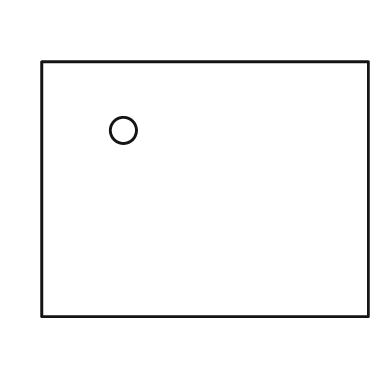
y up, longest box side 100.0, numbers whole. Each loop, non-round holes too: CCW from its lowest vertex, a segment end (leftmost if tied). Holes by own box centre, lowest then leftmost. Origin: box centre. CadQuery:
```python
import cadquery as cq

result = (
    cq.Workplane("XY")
    .moveTo(-50.0, -39.0)
    .lineTo(50.0, -39.0)
    .lineTo(50.0, 39.0)
    .lineTo(-50.0, 39.0)
    .close()
    .moveTo(-25.0, 18.0)
    .circle(4.0)
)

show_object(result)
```